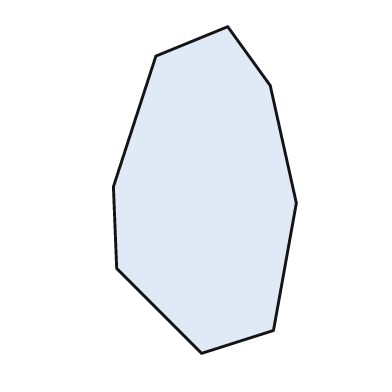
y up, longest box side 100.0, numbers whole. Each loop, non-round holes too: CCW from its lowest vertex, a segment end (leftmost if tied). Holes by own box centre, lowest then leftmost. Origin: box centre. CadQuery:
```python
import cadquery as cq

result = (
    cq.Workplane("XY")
    .moveTo(-1.0, -50.0)
    .lineTo(21.0, -43.0)
    .lineTo(28.0, -4.0)
    .lineTo(20.0, 32.0)
    .lineTo(7.0, 50.0)
    .lineTo(-15.0, 41.0)
    .lineTo(-28.0, 1.0)
    .lineTo(-27.0, -24.0)
    .close()
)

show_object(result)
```